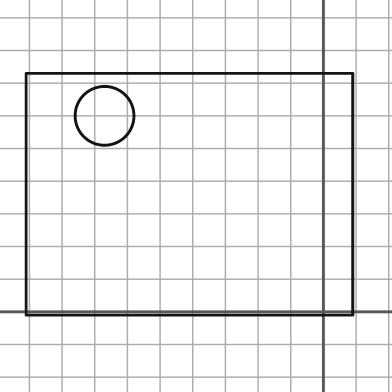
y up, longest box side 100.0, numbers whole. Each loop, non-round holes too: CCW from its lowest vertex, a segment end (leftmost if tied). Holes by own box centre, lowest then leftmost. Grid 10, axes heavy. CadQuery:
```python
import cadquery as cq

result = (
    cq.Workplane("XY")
    .moveTo(-91.0, -1.0)
    .lineTo(9.0, -1.0)
    .lineTo(9.0, 73.0)
    .lineTo(-91.0, 73.0)
    .close()
    .moveTo(-67.0, 60.0)
    .circle(9.0)
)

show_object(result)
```